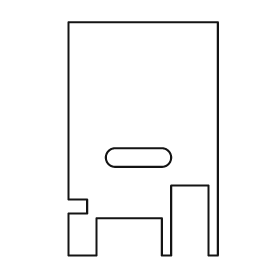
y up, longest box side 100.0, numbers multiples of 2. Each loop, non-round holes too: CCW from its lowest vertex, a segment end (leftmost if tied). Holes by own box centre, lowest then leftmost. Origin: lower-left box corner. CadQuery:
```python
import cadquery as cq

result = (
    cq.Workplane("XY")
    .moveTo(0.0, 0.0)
    .lineTo(12.0, 0.0)
    .lineTo(12.0, 16.0)
    .lineTo(40.0, 16.0)
    .lineTo(40.0, 0.0)
    .lineTo(44.0, 0.0)
    .lineTo(44.0, 30.0)
    .lineTo(60.0, 30.0)
    .lineTo(60.0, 0.0)
    .lineTo(64.0, 0.0)
    .lineTo(64.0, 100.0)
    .lineTo(0.0, 100.0)
    .lineTo(0.0, 24.0)
    .lineTo(8.0, 24.0)
    .lineTo(8.0, 18.0)
    .lineTo(0.0, 18.0)
    .close()
    .moveTo(20.0, 38.0)
    .lineTo(40.0, 38.0)
    .threePointArc((44.0, 42.0), (40.0, 46.0))
    .lineTo(20.0, 46.0)
    .threePointArc((16.0, 42.0), (20.0, 38.0))
    .close()
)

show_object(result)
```